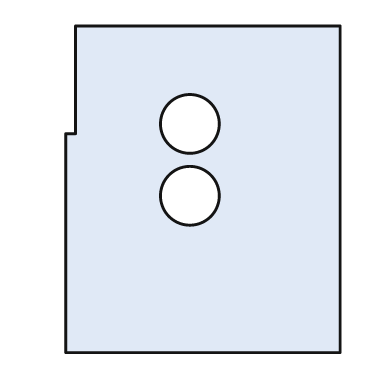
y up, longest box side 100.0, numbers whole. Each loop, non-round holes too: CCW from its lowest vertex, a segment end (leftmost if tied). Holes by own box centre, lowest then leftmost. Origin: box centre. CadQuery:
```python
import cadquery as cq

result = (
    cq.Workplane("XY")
    .moveTo(-42.0, -50.0)
    .lineTo(42.0, -50.0)
    .lineTo(42.0, 50.0)
    .lineTo(-39.0, 50.0)
    .lineTo(-39.0, 17.0)
    .lineTo(-42.0, 17.0)
    .close()
    .moveTo(-4.0, -2.0)
    .circle(9.0)
    .moveTo(-4.0, 20.0)
    .circle(9.0)
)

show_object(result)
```